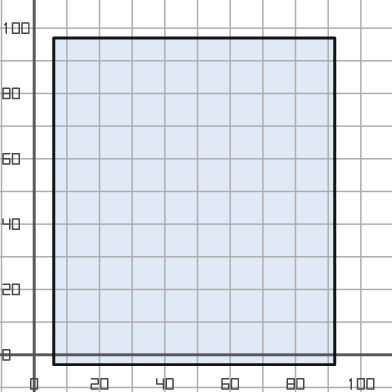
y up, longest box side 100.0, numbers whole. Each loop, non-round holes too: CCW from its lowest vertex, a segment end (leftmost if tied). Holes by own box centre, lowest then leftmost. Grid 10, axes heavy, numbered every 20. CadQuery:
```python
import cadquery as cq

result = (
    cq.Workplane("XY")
    .moveTo(6.0, -3.0)
    .lineTo(92.0, -3.0)
    .lineTo(92.0, 97.0)
    .lineTo(6.0, 97.0)
    .close()
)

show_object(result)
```